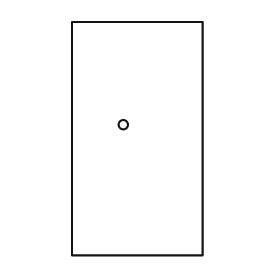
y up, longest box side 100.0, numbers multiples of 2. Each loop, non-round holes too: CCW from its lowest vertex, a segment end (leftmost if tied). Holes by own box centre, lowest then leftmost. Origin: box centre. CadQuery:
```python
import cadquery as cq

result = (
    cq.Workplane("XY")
    .moveTo(-28.0, -50.0)
    .lineTo(28.0, -50.0)
    .lineTo(28.0, 50.0)
    .lineTo(-28.0, 50.0)
    .close()
    .moveTo(-6.0, 6.0)
    .circle(2.0)
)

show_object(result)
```